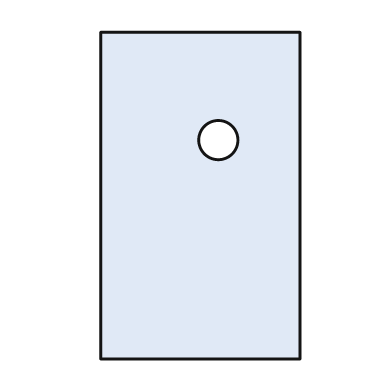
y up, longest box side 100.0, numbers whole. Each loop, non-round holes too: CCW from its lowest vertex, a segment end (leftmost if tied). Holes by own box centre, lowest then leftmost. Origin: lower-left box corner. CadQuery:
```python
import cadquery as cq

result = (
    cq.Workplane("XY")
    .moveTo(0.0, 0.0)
    .lineTo(61.0, 0.0)
    .lineTo(61.0, 100.0)
    .lineTo(0.0, 100.0)
    .close()
    .moveTo(36.0, 67.0)
    .circle(6.0)
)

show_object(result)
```